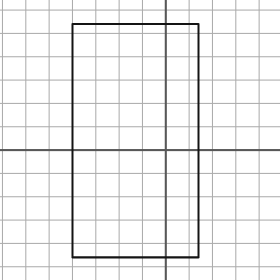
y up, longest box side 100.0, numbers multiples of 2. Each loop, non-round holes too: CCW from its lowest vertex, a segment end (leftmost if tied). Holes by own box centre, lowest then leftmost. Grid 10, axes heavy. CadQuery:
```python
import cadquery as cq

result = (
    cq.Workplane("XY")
    .moveTo(-40.0, -46.0)
    .lineTo(14.0, -46.0)
    .lineTo(14.0, 54.0)
    .lineTo(-40.0, 54.0)
    .close()
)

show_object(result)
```